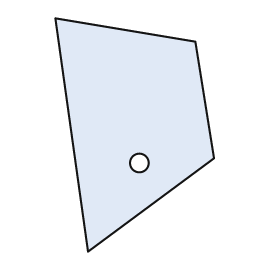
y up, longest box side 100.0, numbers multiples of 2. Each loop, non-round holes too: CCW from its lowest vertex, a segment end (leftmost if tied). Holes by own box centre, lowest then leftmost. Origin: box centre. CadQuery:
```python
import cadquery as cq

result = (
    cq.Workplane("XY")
    .moveTo(-20.0, -50.0)
    .lineTo(34.0, -10.0)
    .lineTo(26.0, 40.0)
    .lineTo(-34.0, 50.0)
    .close()
    .moveTo(2.0, -12.0)
    .circle(4.0)
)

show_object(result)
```